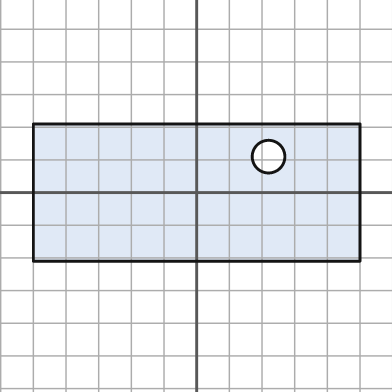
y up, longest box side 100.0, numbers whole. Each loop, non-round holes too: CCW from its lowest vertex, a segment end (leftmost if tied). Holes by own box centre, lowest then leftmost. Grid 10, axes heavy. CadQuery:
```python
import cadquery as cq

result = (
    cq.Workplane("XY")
    .moveTo(-50.0, -21.0)
    .lineTo(50.0, -21.0)
    .lineTo(50.0, 21.0)
    .lineTo(-50.0, 21.0)
    .close()
    .moveTo(22.0, 11.0)
    .circle(5.0)
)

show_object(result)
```